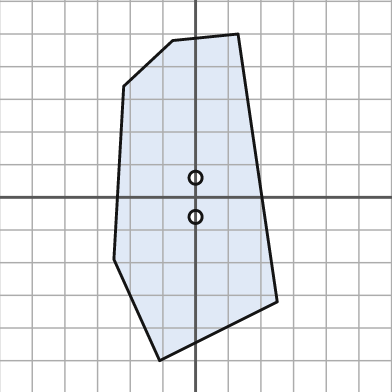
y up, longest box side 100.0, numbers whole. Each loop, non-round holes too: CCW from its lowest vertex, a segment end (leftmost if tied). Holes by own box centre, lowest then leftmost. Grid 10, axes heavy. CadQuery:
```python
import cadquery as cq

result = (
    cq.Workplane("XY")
    .moveTo(-11.0, -50.0)
    .lineTo(25.0, -32.0)
    .lineTo(13.0, 50.0)
    .lineTo(-7.0, 48.0)
    .lineTo(-22.0, 34.0)
    .lineTo(-25.0, -19.0)
    .close()
    .moveTo(0.0, -6.0)
    .circle(2.0)
    .moveTo(0.0, 6.0)
    .circle(2.0)
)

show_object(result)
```